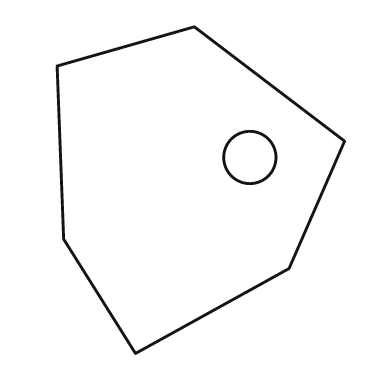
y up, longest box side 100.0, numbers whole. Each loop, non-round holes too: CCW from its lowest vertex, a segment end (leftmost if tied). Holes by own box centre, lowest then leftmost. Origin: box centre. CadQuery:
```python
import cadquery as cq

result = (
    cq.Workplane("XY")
    .moveTo(-20.0, -50.0)
    .lineTo(27.0, -24.0)
    .lineTo(44.0, 15.0)
    .lineTo(-2.0, 50.0)
    .lineTo(-44.0, 38.0)
    .lineTo(-42.0, -15.0)
    .close()
    .moveTo(15.0, 10.0)
    .circle(8.0)
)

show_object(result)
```